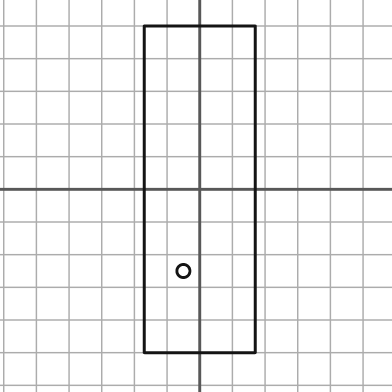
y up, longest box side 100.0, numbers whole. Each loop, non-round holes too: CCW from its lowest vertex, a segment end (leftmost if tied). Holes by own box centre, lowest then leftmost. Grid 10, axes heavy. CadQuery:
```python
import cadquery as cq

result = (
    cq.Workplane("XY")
    .moveTo(-17.0, -50.0)
    .lineTo(17.0, -50.0)
    .lineTo(17.0, 50.0)
    .lineTo(-17.0, 50.0)
    .close()
    .moveTo(-5.0, -25.0)
    .circle(2.0)
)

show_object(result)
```